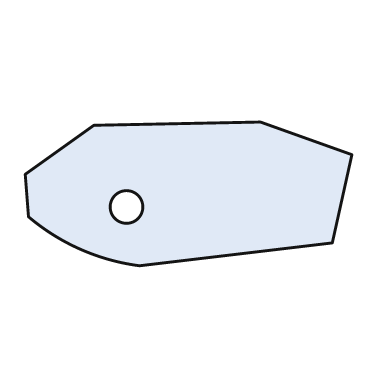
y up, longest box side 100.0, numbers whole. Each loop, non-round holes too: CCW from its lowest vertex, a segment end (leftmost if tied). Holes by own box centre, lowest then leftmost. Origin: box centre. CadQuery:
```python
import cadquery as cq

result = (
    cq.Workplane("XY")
    .moveTo(-15.0, -22.0)
    .lineTo(44.0, -15.0)
    .lineTo(50.0, 12.0)
    .lineTo(22.0, 22.0)
    .lineTo(-29.0, 21.0)
    .lineTo(-50.0, 6.0)
    .lineTo(-49.0, -7.0)
    .threePointArc((-33.0, -17.0), (-15.0, -22.0))
    .close()
    .moveTo(-19.0, -4.0)
    .circle(5.0)
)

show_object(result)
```